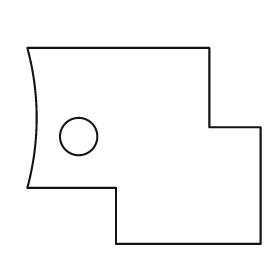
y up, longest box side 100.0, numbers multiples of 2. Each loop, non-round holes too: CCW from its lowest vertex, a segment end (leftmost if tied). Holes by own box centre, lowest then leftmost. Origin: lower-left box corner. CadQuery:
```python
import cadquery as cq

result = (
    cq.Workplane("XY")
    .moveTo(38.0, 0.0)
    .lineTo(100.0, 0.0)
    .lineTo(100.0, 50.0)
    .lineTo(78.0, 50.0)
    .lineTo(78.0, 84.0)
    .lineTo(0.0, 84.0)
    .threePointArc((4.0, 54.0), (0.0, 24.0))
    .lineTo(38.0, 24.0)
    .close()
    .moveTo(22.0, 46.0)
    .circle(8.0)
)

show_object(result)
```